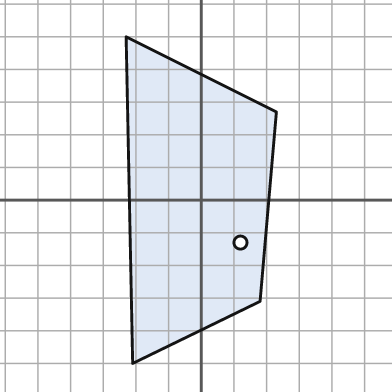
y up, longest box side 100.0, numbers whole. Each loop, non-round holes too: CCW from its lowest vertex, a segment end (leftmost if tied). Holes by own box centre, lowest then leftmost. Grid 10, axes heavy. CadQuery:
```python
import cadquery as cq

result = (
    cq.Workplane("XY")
    .moveTo(-21.0, -50.0)
    .lineTo(18.0, -31.0)
    .lineTo(23.0, 27.0)
    .lineTo(-23.0, 50.0)
    .close()
    .moveTo(12.0, -13.0)
    .circle(2.0)
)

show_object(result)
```